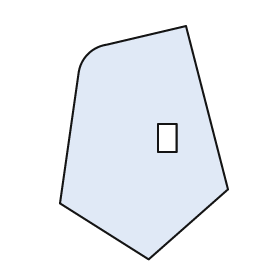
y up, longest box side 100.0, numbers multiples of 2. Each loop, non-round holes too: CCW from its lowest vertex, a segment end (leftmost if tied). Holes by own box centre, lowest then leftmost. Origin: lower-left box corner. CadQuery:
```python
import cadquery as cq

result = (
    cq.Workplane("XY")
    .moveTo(38.0, 0.0)
    .lineTo(72.0, 30.0)
    .lineTo(54.0, 100.0)
    .lineTo(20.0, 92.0)
    .threePointArc((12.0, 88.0), (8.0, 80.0))
    .lineTo(0.0, 24.0)
    .close()
    .moveTo(42.0, 46.0)
    .lineTo(50.0, 46.0)
    .lineTo(50.0, 58.0)
    .lineTo(42.0, 58.0)
    .close()
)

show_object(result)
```